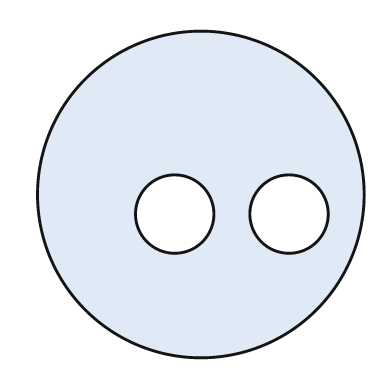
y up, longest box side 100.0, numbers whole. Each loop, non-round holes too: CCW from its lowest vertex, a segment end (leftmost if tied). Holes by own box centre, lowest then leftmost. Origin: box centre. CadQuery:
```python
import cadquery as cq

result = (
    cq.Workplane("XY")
    .moveTo(0.0, 0.0)
    .circle(50.0)
    .moveTo(-8.0, -6.0)
    .circle(12.0)
    .moveTo(27.0, -6.0)
    .circle(12.0)
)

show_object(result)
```